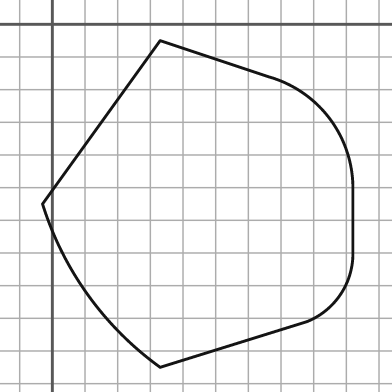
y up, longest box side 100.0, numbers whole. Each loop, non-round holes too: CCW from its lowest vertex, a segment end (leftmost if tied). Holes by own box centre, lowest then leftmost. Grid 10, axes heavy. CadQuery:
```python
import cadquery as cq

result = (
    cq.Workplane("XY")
    .moveTo(33.0, -105.0)
    .lineTo(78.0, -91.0)
    .threePointArc((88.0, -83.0), (92.0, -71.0))
    .lineTo(92.0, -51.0)
    .threePointArc((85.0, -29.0), (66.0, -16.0))
    .lineTo(33.0, -5.0)
    .lineTo(-3.0, -55.0)
    .threePointArc((11.0, -83.0), (33.0, -105.0))
    .close()
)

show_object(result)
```